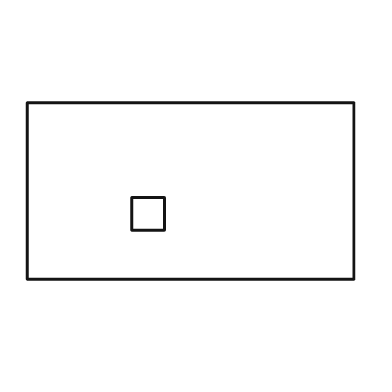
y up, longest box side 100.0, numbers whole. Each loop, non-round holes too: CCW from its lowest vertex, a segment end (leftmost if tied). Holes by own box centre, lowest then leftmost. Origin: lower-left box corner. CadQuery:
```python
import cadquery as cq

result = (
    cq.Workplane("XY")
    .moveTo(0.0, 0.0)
    .lineTo(100.0, 0.0)
    .lineTo(100.0, 54.0)
    .lineTo(0.0, 54.0)
    .close()
    .moveTo(32.0, 15.0)
    .lineTo(42.0, 15.0)
    .lineTo(42.0, 25.0)
    .lineTo(32.0, 25.0)
    .close()
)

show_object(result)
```